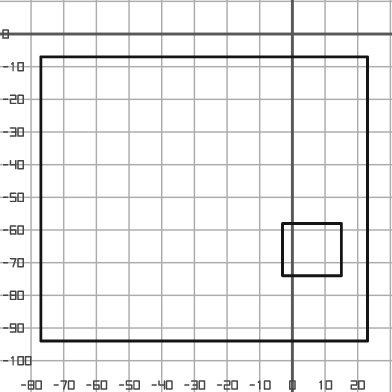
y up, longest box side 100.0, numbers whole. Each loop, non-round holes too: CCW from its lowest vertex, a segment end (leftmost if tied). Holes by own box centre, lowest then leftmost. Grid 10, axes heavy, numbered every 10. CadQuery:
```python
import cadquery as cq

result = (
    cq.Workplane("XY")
    .moveTo(-77.0, -94.0)
    .lineTo(23.0, -94.0)
    .lineTo(23.0, -7.0)
    .lineTo(-77.0, -7.0)
    .close()
    .moveTo(-3.0, -74.0)
    .lineTo(15.0, -74.0)
    .lineTo(15.0, -58.0)
    .lineTo(-3.0, -58.0)
    .close()
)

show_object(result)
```